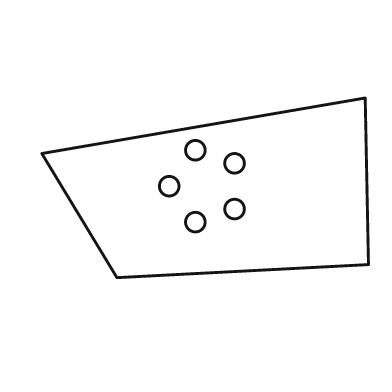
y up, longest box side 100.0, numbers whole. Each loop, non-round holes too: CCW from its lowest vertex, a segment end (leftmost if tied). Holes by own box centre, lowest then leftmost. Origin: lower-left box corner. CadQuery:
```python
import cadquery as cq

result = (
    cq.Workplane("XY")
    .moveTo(23.0, 0.0)
    .lineTo(100.0, 4.0)
    .lineTo(99.0, 55.0)
    .lineTo(0.0, 38.0)
    .close()
    .moveTo(47.0, 17.0)
    .circle(3.0)
    .moveTo(59.0, 21.0)
    .circle(3.0)
    .moveTo(39.0, 28.0)
    .circle(3.0)
    .moveTo(59.0, 35.0)
    .circle(3.0)
    .moveTo(47.0, 39.0)
    .circle(3.0)
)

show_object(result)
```